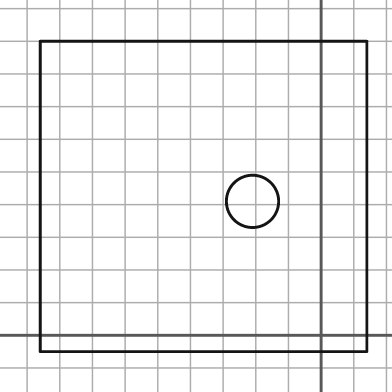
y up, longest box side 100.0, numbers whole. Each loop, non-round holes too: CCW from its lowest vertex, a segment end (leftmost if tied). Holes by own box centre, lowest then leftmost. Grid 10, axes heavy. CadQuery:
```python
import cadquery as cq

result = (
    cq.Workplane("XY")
    .moveTo(-86.0, -5.0)
    .lineTo(14.0, -5.0)
    .lineTo(14.0, 90.0)
    .lineTo(-86.0, 90.0)
    .close()
    .moveTo(-21.0, 41.0)
    .circle(8.0)
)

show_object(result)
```